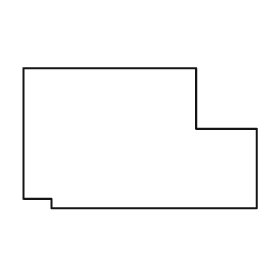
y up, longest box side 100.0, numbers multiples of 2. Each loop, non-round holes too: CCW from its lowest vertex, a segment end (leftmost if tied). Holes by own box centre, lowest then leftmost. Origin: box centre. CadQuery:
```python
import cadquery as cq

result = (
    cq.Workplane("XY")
    .moveTo(-38.0, -30.0)
    .lineTo(50.0, -30.0)
    .lineTo(50.0, 4.0)
    .lineTo(24.0, 4.0)
    .lineTo(24.0, 30.0)
    .lineTo(-50.0, 30.0)
    .lineTo(-50.0, -26.0)
    .lineTo(-38.0, -26.0)
    .close()
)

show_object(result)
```